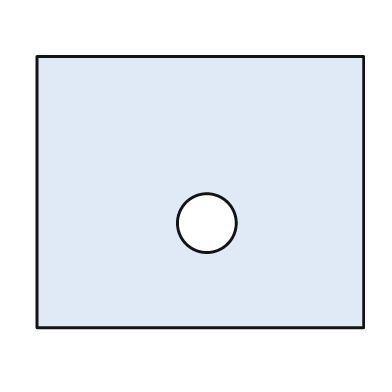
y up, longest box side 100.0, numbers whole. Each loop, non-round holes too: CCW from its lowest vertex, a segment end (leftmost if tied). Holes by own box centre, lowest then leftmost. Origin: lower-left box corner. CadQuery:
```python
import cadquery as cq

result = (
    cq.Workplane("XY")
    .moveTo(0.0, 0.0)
    .lineTo(100.0, 0.0)
    .lineTo(100.0, 83.0)
    .lineTo(0.0, 83.0)
    .close()
    .moveTo(52.0, 32.0)
    .circle(9.0)
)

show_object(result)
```